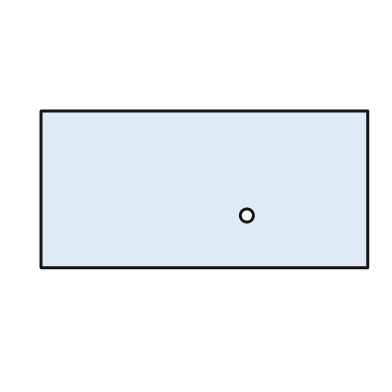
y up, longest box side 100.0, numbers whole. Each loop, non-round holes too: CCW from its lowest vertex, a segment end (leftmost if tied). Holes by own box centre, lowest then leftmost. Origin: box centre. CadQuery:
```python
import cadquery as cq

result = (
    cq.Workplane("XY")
    .moveTo(-50.0, -24.0)
    .lineTo(50.0, -24.0)
    .lineTo(50.0, 24.0)
    .lineTo(-50.0, 24.0)
    .close()
    .moveTo(13.0, -8.0)
    .circle(2.0)
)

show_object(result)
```